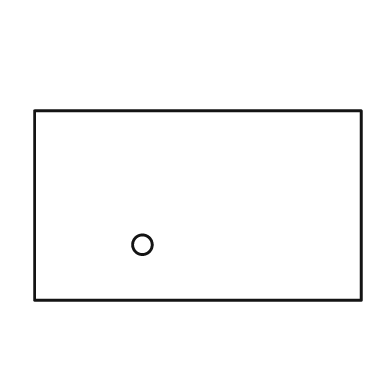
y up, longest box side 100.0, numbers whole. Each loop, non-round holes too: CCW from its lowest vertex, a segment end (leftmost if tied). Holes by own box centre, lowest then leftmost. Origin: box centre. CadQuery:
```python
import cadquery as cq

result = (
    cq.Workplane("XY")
    .moveTo(-50.0, -29.0)
    .lineTo(50.0, -29.0)
    .lineTo(50.0, 29.0)
    .lineTo(-50.0, 29.0)
    .close()
    .moveTo(-17.0, -12.0)
    .circle(3.0)
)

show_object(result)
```